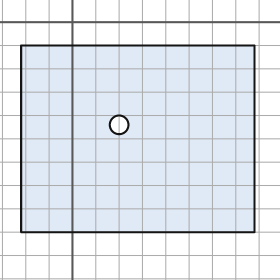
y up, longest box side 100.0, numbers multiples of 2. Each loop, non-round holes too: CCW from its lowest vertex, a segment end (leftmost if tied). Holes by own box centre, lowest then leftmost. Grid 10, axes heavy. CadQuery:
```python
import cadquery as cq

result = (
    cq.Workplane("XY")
    .moveTo(-22.0, -90.0)
    .lineTo(78.0, -90.0)
    .lineTo(78.0, -10.0)
    .lineTo(-22.0, -10.0)
    .close()
    .moveTo(20.0, -44.0)
    .circle(4.0)
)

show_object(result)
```